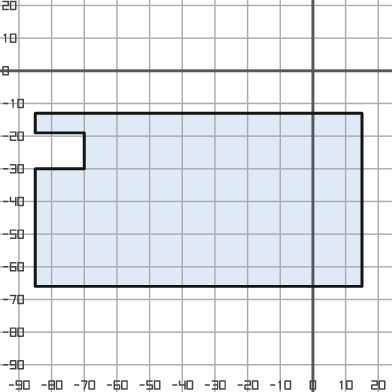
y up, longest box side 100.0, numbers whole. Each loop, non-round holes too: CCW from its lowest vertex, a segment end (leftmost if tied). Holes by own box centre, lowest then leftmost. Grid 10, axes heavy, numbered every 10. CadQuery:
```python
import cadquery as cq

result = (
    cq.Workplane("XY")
    .moveTo(-85.0, -66.0)
    .lineTo(15.0, -66.0)
    .lineTo(15.0, -13.0)
    .lineTo(-85.0, -13.0)
    .lineTo(-85.0, -19.0)
    .lineTo(-70.0, -19.0)
    .lineTo(-70.0, -30.0)
    .lineTo(-85.0, -30.0)
    .close()
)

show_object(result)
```